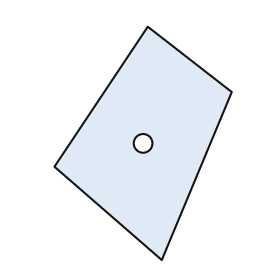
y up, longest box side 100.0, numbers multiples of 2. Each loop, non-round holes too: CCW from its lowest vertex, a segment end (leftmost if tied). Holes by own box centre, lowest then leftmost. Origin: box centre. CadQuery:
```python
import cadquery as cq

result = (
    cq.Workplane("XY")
    .moveTo(8.0, -50.0)
    .lineTo(38.0, 22.0)
    .lineTo(2.0, 50.0)
    .lineTo(-38.0, -10.0)
    .close()
    .moveTo(0.0, 0.0)
    .circle(4.0)
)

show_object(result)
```